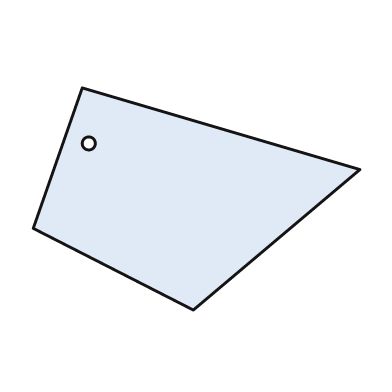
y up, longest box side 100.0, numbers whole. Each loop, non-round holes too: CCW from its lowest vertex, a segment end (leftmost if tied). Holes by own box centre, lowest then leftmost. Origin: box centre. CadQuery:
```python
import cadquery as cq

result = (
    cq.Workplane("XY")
    .moveTo(-1.0, -34.0)
    .lineTo(50.0, 9.0)
    .lineTo(-35.0, 34.0)
    .lineTo(-50.0, -9.0)
    .close()
    .moveTo(-33.0, 17.0)
    .circle(2.0)
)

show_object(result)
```